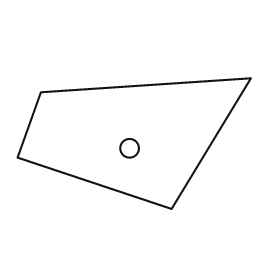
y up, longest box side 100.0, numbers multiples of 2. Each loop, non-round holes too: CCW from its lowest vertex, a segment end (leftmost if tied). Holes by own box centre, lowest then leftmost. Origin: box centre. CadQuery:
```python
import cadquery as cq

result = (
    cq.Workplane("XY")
    .moveTo(16.0, -28.0)
    .lineTo(50.0, 28.0)
    .lineTo(-40.0, 22.0)
    .lineTo(-50.0, -6.0)
    .close()
    .moveTo(-2.0, -2.0)
    .circle(4.0)
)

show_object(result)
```